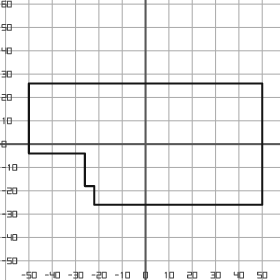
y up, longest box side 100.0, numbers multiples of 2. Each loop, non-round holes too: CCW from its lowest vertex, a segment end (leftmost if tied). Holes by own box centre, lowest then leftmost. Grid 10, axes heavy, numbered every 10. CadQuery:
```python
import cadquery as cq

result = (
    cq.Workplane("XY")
    .moveTo(-22.0, -26.0)
    .lineTo(50.0, -26.0)
    .lineTo(50.0, 26.0)
    .lineTo(-50.0, 26.0)
    .lineTo(-50.0, -4.0)
    .lineTo(-26.0, -4.0)
    .lineTo(-26.0, -18.0)
    .lineTo(-22.0, -18.0)
    .close()
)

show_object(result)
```